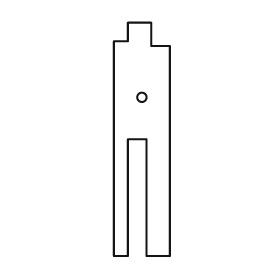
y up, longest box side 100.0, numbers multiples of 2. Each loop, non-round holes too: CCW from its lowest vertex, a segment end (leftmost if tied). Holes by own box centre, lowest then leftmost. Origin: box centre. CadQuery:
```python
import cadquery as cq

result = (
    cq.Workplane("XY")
    .moveTo(-12.0, -50.0)
    .lineTo(-6.0, -50.0)
    .lineTo(-6.0, 0.0)
    .lineTo(2.0, 0.0)
    .lineTo(2.0, -50.0)
    .lineTo(12.0, -50.0)
    .lineTo(12.0, 40.0)
    .lineTo(4.0, 40.0)
    .lineTo(4.0, 50.0)
    .lineTo(-6.0, 50.0)
    .lineTo(-6.0, 42.0)
    .lineTo(-12.0, 42.0)
    .close()
    .moveTo(0.0, 18.0)
    .circle(2.0)
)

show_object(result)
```